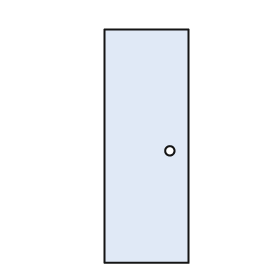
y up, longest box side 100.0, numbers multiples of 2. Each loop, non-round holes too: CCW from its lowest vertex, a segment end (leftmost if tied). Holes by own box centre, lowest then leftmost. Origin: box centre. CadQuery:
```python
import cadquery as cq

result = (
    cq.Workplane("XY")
    .moveTo(-18.0, -50.0)
    .lineTo(18.0, -50.0)
    .lineTo(18.0, 50.0)
    .lineTo(-18.0, 50.0)
    .close()
    .moveTo(10.0, -2.0)
    .circle(2.0)
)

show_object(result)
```